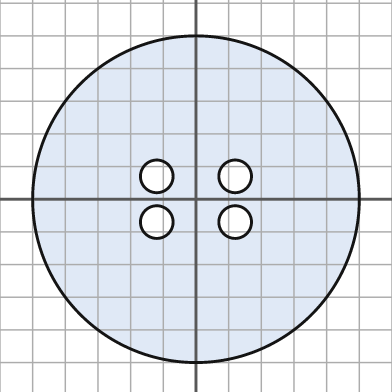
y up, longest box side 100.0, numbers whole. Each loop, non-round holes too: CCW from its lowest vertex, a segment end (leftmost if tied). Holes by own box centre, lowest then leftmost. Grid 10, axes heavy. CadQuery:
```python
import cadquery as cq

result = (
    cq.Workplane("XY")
    .moveTo(0.0, 0.0)
    .circle(50.0)
    .moveTo(-12.0, -7.0)
    .circle(5.0)
    .moveTo(12.0, -7.0)
    .circle(5.0)
    .moveTo(-12.0, 7.0)
    .circle(5.0)
    .moveTo(12.0, 7.0)
    .circle(5.0)
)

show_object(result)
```